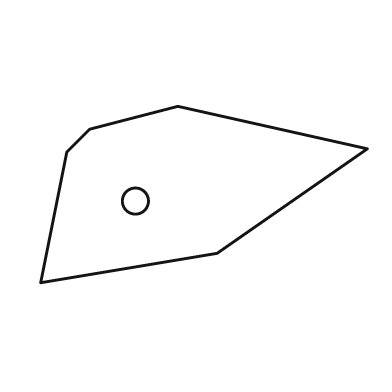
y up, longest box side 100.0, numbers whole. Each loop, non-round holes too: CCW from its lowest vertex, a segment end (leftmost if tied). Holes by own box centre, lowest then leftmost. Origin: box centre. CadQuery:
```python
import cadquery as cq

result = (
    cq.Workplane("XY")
    .moveTo(-50.0, -27.0)
    .lineTo(4.0, -18.0)
    .lineTo(50.0, 14.0)
    .lineTo(-8.0, 27.0)
    .lineTo(-35.0, 20.0)
    .lineTo(-42.0, 13.0)
    .close()
    .moveTo(-21.0, -2.0)
    .circle(4.0)
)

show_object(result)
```